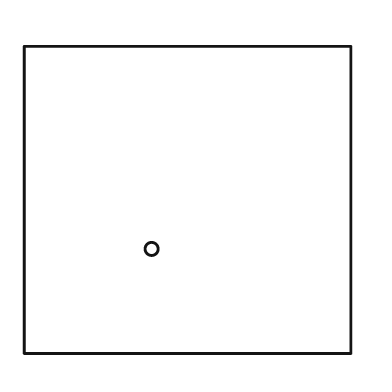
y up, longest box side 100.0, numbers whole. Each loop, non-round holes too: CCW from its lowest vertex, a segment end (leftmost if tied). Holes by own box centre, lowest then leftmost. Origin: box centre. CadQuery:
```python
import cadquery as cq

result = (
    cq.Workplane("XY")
    .moveTo(-50.0, -47.0)
    .lineTo(50.0, -47.0)
    .lineTo(50.0, 47.0)
    .lineTo(-50.0, 47.0)
    .close()
    .moveTo(-11.0, -15.0)
    .circle(2.0)
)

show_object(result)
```